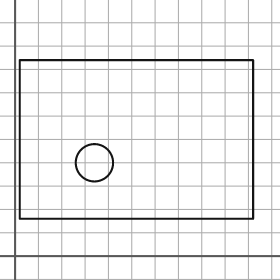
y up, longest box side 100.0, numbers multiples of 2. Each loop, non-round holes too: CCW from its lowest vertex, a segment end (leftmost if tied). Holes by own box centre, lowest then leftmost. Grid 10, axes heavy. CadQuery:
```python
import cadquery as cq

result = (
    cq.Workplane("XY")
    .moveTo(2.0, 16.0)
    .lineTo(102.0, 16.0)
    .lineTo(102.0, 84.0)
    .lineTo(2.0, 84.0)
    .close()
    .moveTo(34.0, 40.0)
    .circle(8.0)
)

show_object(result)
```